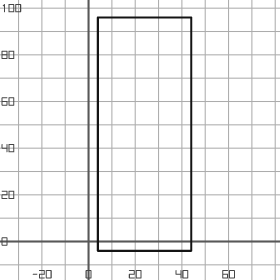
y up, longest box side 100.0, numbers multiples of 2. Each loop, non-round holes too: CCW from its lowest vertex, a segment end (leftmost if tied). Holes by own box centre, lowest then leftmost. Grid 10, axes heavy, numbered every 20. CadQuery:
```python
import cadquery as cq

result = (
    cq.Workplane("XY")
    .moveTo(4.0, -4.0)
    .lineTo(44.0, -4.0)
    .lineTo(44.0, 96.0)
    .lineTo(4.0, 96.0)
    .close()
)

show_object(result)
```